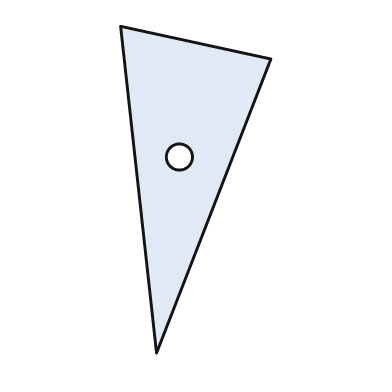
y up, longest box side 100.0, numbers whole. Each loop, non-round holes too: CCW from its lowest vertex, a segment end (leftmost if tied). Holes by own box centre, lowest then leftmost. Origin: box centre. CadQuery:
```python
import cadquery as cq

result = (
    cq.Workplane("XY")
    .moveTo(-12.0, -50.0)
    .lineTo(23.0, 40.0)
    .lineTo(-23.0, 50.0)
    .close()
    .moveTo(-5.0, 10.0)
    .circle(4.0)
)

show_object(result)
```